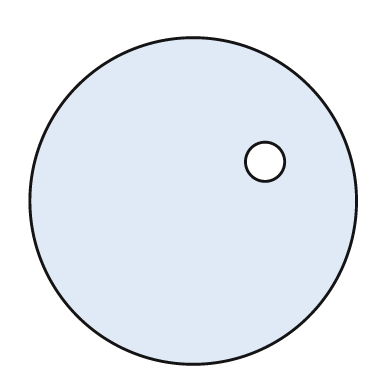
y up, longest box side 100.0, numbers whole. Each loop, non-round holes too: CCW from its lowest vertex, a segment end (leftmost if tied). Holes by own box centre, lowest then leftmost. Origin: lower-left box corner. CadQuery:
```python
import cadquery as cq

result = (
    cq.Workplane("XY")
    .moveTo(50.0, 50.0)
    .circle(50.0)
    .moveTo(72.0, 62.0)
    .circle(6.0)
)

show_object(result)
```